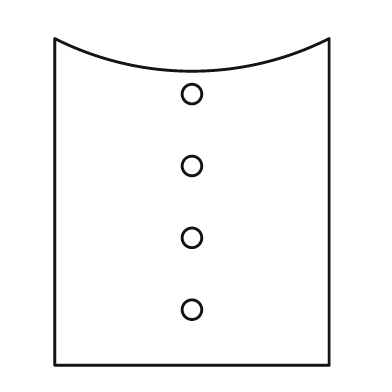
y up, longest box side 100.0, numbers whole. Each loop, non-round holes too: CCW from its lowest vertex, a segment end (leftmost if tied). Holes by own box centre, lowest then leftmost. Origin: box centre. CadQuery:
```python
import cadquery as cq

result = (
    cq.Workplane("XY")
    .moveTo(-42.0, -50.0)
    .lineTo(42.0, -50.0)
    .lineTo(42.0, 50.0)
    .threePointArc((0.0, 40.0), (-42.0, 50.0))
    .close()
    .moveTo(0.0, -33.0)
    .circle(3.0)
    .moveTo(0.0, -11.0)
    .circle(3.0)
    .moveTo(0.0, 11.0)
    .circle(3.0)
    .moveTo(0.0, 33.0)
    .circle(3.0)
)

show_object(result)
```